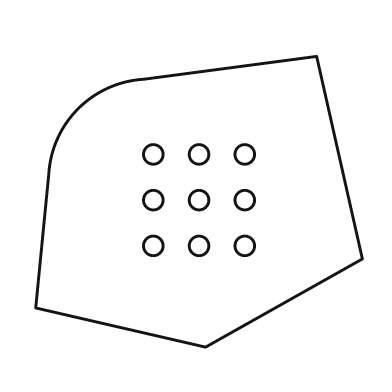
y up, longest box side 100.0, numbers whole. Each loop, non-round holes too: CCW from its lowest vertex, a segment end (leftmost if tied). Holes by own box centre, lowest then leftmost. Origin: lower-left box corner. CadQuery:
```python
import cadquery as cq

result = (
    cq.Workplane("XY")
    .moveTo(52.0, 0.0)
    .lineTo(100.0, 27.0)
    .lineTo(86.0, 89.0)
    .lineTo(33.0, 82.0)
    .threePointArc((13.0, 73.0), (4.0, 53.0))
    .lineTo(0.0, 12.0)
    .close()
    .moveTo(36.0, 31.0)
    .circle(3.0)
    .moveTo(50.0, 31.0)
    .circle(3.0)
    .moveTo(64.0, 31.0)
    .circle(3.0)
    .moveTo(36.0, 45.0)
    .circle(3.0)
    .moveTo(50.0, 45.0)
    .circle(3.0)
    .moveTo(64.0, 45.0)
    .circle(3.0)
    .moveTo(36.0, 59.0)
    .circle(3.0)
    .moveTo(50.0, 59.0)
    .circle(3.0)
    .moveTo(64.0, 59.0)
    .circle(3.0)
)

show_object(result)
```